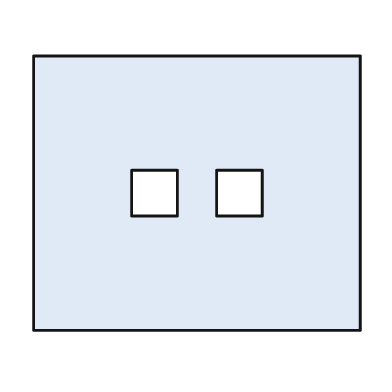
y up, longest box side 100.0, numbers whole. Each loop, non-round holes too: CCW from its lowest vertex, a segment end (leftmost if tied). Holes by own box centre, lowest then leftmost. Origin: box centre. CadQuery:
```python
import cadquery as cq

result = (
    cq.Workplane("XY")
    .moveTo(-50.0, -42.0)
    .lineTo(50.0, -42.0)
    .lineTo(50.0, 42.0)
    .lineTo(-50.0, 42.0)
    .close()
    .moveTo(-20.0, -7.0)
    .lineTo(-6.0, -7.0)
    .lineTo(-6.0, 7.0)
    .lineTo(-20.0, 7.0)
    .close()
    .moveTo(6.0, -7.0)
    .lineTo(20.0, -7.0)
    .lineTo(20.0, 7.0)
    .lineTo(6.0, 7.0)
    .close()
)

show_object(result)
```